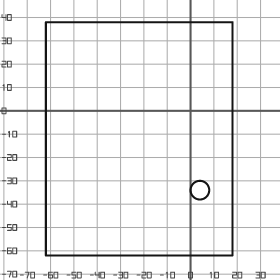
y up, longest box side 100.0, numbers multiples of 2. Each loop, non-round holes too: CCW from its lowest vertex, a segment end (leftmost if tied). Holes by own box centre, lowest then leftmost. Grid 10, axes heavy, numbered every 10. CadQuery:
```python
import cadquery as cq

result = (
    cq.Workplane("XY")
    .moveTo(-62.0, -62.0)
    .lineTo(18.0, -62.0)
    .lineTo(18.0, 38.0)
    .lineTo(-62.0, 38.0)
    .close()
    .moveTo(4.0, -34.0)
    .circle(4.0)
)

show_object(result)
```